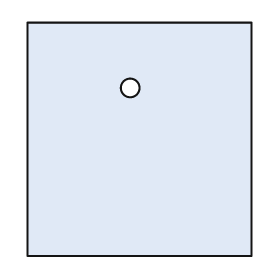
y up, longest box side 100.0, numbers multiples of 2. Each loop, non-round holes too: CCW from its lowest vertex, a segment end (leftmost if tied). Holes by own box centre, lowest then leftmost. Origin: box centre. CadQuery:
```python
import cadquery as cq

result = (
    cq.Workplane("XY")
    .moveTo(-48.0, -50.0)
    .lineTo(48.0, -50.0)
    .lineTo(48.0, 50.0)
    .lineTo(-48.0, 50.0)
    .close()
    .moveTo(-4.0, 22.0)
    .circle(4.0)
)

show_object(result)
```